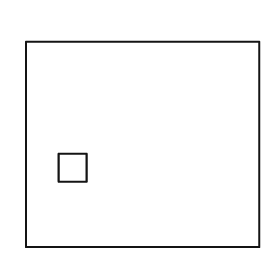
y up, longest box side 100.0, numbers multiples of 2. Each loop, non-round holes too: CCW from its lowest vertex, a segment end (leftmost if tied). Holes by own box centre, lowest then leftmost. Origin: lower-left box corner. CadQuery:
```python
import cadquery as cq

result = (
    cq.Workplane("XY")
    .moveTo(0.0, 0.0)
    .lineTo(100.0, 0.0)
    .lineTo(100.0, 88.0)
    .lineTo(0.0, 88.0)
    .close()
    .moveTo(14.0, 28.0)
    .lineTo(26.0, 28.0)
    .lineTo(26.0, 40.0)
    .lineTo(14.0, 40.0)
    .close()
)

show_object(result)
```